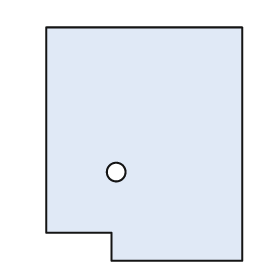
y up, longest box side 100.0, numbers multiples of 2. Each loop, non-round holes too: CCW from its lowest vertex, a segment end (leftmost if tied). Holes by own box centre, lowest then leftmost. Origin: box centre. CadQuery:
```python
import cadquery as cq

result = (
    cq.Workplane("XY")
    .moveTo(-14.0, -50.0)
    .lineTo(42.0, -50.0)
    .lineTo(42.0, 50.0)
    .lineTo(-42.0, 50.0)
    .lineTo(-42.0, -38.0)
    .lineTo(-14.0, -38.0)
    .close()
    .moveTo(-12.0, -12.0)
    .circle(4.0)
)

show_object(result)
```